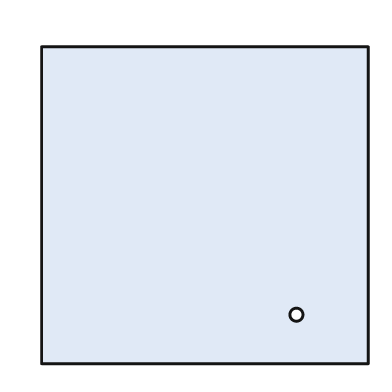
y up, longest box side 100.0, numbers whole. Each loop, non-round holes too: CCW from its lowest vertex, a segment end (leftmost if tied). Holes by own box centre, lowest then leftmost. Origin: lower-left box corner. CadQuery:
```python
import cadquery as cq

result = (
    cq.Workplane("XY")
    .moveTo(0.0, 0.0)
    .lineTo(100.0, 0.0)
    .lineTo(100.0, 97.0)
    .lineTo(0.0, 97.0)
    .close()
    .moveTo(78.0, 15.0)
    .circle(2.0)
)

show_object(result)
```